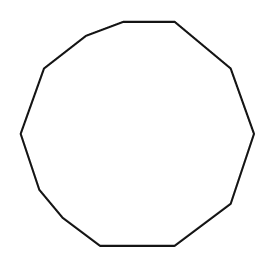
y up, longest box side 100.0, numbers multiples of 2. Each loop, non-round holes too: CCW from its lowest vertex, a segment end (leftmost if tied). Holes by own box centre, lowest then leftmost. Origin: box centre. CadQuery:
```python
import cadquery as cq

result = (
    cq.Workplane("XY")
    .moveTo(-16.0, -48.0)
    .lineTo(16.0, -48.0)
    .lineTo(40.0, -30.0)
    .lineTo(50.0, 0.0)
    .lineTo(40.0, 28.0)
    .lineTo(16.0, 48.0)
    .lineTo(-6.0, 48.0)
    .lineTo(-22.0, 42.0)
    .lineTo(-40.0, 28.0)
    .lineTo(-50.0, 0.0)
    .lineTo(-42.0, -24.0)
    .lineTo(-32.0, -36.0)
    .close()
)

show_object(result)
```